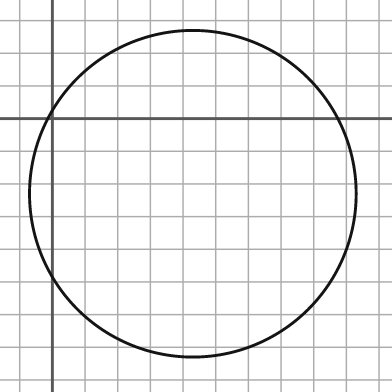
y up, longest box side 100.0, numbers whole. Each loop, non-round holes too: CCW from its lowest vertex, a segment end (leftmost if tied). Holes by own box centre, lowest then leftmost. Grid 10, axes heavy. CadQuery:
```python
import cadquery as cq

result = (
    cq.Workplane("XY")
    .moveTo(43.0, -23.0)
    .circle(50.0)
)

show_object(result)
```